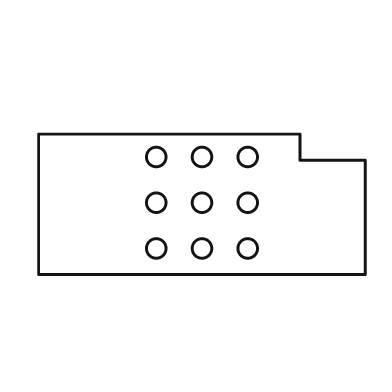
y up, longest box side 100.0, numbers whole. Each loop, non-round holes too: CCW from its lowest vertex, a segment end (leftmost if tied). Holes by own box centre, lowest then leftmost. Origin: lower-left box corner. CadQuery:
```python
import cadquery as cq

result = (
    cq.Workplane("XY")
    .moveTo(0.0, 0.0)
    .lineTo(100.0, 0.0)
    .lineTo(100.0, 35.0)
    .lineTo(80.0, 35.0)
    .lineTo(80.0, 43.0)
    .lineTo(0.0, 43.0)
    .close()
    .moveTo(36.0, 8.0)
    .circle(3.0)
    .moveTo(50.0, 8.0)
    .circle(3.0)
    .moveTo(64.0, 8.0)
    .circle(3.0)
    .moveTo(36.0, 22.0)
    .circle(3.0)
    .moveTo(50.0, 22.0)
    .circle(3.0)
    .moveTo(64.0, 22.0)
    .circle(3.0)
    .moveTo(36.0, 36.0)
    .circle(3.0)
    .moveTo(50.0, 36.0)
    .circle(3.0)
    .moveTo(64.0, 36.0)
    .circle(3.0)
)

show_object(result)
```